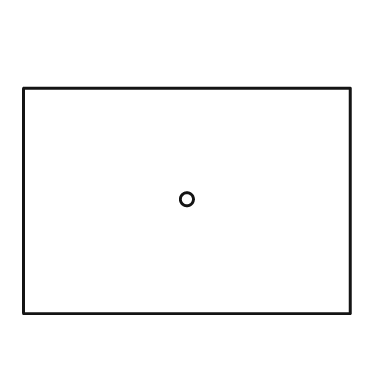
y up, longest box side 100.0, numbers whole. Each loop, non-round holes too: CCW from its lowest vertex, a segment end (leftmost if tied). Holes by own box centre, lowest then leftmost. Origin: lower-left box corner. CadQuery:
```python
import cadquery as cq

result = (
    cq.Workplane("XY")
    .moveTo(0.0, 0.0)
    .lineTo(100.0, 0.0)
    .lineTo(100.0, 69.0)
    .lineTo(0.0, 69.0)
    .close()
    .moveTo(50.0, 35.0)
    .circle(2.0)
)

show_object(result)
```